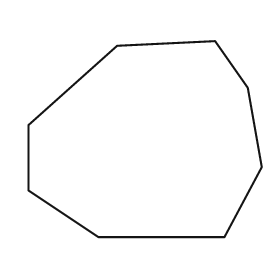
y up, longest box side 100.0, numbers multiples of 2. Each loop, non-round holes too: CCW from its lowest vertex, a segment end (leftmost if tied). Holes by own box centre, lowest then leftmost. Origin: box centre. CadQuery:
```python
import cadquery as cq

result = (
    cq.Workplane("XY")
    .moveTo(-20.0, -42.0)
    .lineTo(34.0, -42.0)
    .lineTo(50.0, -12.0)
    .lineTo(44.0, 22.0)
    .lineTo(30.0, 42.0)
    .lineTo(-12.0, 40.0)
    .lineTo(-50.0, 6.0)
    .lineTo(-50.0, -22.0)
    .close()
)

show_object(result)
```